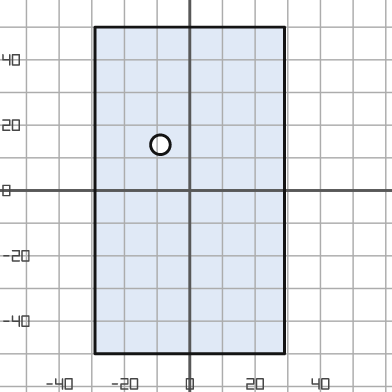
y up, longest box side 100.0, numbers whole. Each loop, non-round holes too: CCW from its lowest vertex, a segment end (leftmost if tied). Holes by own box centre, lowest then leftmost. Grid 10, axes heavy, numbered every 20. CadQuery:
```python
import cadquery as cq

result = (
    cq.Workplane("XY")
    .moveTo(-29.0, -50.0)
    .lineTo(29.0, -50.0)
    .lineTo(29.0, 50.0)
    .lineTo(-29.0, 50.0)
    .close()
    .moveTo(-9.0, 14.0)
    .circle(3.0)
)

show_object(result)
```